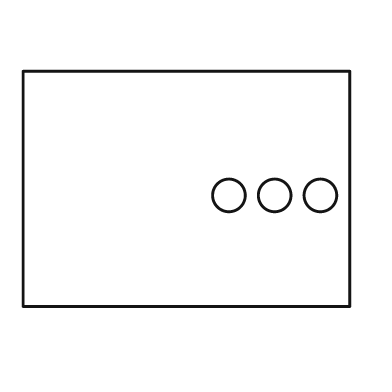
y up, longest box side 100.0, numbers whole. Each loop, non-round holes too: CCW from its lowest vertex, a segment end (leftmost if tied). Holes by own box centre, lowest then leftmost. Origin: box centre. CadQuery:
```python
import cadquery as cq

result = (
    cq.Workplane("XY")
    .moveTo(-50.0, -36.0)
    .lineTo(50.0, -36.0)
    .lineTo(50.0, 36.0)
    .lineTo(-50.0, 36.0)
    .close()
    .moveTo(13.0, -2.0)
    .circle(5.0)
    .moveTo(27.0, -2.0)
    .circle(5.0)
    .moveTo(41.0, -2.0)
    .circle(5.0)
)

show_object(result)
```